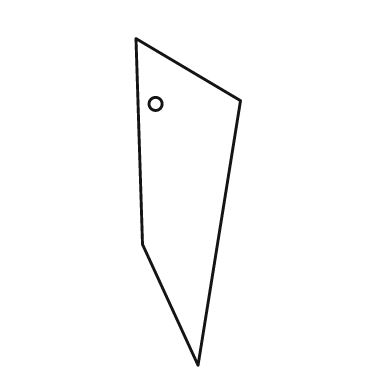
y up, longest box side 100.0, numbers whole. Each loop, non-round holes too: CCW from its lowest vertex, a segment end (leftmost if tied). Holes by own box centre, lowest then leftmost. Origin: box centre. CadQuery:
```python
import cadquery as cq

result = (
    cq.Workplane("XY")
    .moveTo(3.0, -50.0)
    .lineTo(16.0, 31.0)
    .lineTo(-16.0, 50.0)
    .lineTo(-14.0, -13.0)
    .close()
    .moveTo(-10.0, 30.0)
    .circle(2.0)
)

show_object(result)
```